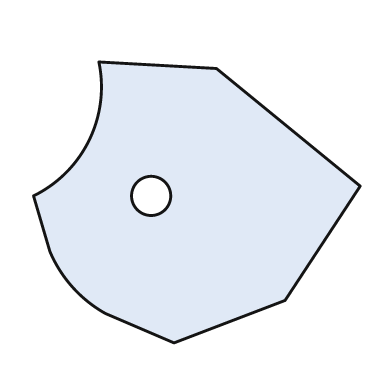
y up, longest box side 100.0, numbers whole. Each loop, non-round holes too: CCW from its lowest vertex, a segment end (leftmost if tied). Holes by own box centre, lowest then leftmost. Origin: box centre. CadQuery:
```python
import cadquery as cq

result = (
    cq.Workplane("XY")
    .moveTo(-7.0, -43.0)
    .lineTo(27.0, -30.0)
    .lineTo(50.0, 5.0)
    .lineTo(6.0, 41.0)
    .lineTo(-30.0, 43.0)
    .threePointArc((-33.0, 19.0), (-50.0, 2.0))
    .lineTo(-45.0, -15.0)
    .threePointArc((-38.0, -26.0), (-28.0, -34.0))
    .close()
    .moveTo(-14.0, 2.0)
    .circle(6.0)
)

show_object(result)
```